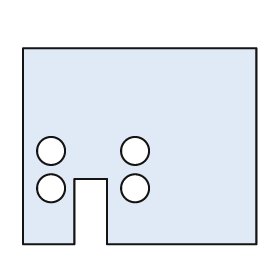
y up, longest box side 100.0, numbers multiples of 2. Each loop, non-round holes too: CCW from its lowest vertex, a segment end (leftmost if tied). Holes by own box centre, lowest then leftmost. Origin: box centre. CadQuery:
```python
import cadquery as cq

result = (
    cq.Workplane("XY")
    .moveTo(-50.0, -42.0)
    .lineTo(-28.0, -42.0)
    .lineTo(-28.0, -14.0)
    .lineTo(-14.0, -14.0)
    .lineTo(-14.0, -42.0)
    .lineTo(50.0, -42.0)
    .lineTo(50.0, 42.0)
    .lineTo(-50.0, 42.0)
    .close()
    .moveTo(-38.0, -18.0)
    .circle(6.0)
    .moveTo(-2.0, -18.0)
    .circle(6.0)
    .moveTo(-38.0, -2.0)
    .circle(6.0)
    .moveTo(-2.0, -2.0)
    .circle(6.0)
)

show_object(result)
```